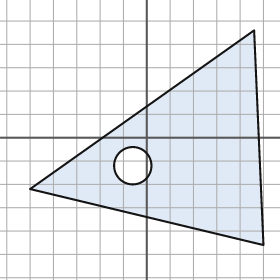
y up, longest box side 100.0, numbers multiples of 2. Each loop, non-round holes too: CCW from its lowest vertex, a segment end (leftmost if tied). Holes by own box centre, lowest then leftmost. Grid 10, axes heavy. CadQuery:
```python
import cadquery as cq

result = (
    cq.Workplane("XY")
    .moveTo(50.0, -46.0)
    .lineTo(46.0, 46.0)
    .lineTo(-50.0, -22.0)
    .close()
    .moveTo(-6.0, -12.0)
    .circle(8.0)
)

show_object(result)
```